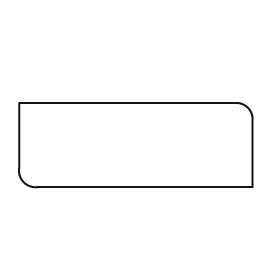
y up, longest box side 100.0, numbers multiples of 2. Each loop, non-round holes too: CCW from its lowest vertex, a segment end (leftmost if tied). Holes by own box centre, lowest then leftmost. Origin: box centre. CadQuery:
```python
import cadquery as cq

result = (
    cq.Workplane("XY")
    .moveTo(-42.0, -18.0)
    .lineTo(50.0, -18.0)
    .lineTo(50.0, 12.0)
    .threePointArc((48.0, 16.0), (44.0, 18.0))
    .lineTo(-50.0, 18.0)
    .lineTo(-50.0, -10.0)
    .threePointArc((-48.0, -16.0), (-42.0, -18.0))
    .close()
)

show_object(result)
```